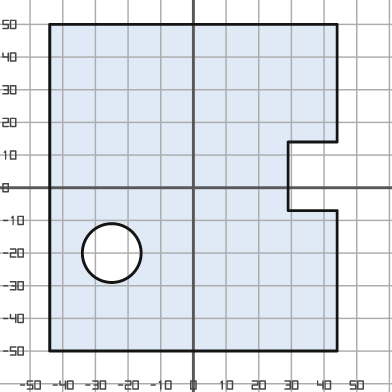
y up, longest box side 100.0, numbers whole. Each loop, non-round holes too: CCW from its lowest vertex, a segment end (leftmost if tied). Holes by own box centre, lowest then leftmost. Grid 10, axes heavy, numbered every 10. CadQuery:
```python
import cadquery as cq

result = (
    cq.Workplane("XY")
    .moveTo(-44.0, -50.0)
    .lineTo(44.0, -50.0)
    .lineTo(44.0, -7.0)
    .lineTo(29.0, -7.0)
    .lineTo(29.0, 14.0)
    .lineTo(44.0, 14.0)
    .lineTo(44.0, 50.0)
    .lineTo(-44.0, 50.0)
    .close()
    .moveTo(-25.0, -20.0)
    .circle(9.0)
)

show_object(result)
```